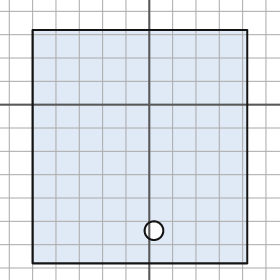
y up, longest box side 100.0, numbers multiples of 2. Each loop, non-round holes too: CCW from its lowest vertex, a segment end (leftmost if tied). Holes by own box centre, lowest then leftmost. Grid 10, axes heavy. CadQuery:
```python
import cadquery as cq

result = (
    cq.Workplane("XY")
    .moveTo(-50.0, -68.0)
    .lineTo(42.0, -68.0)
    .lineTo(42.0, 32.0)
    .lineTo(-50.0, 32.0)
    .close()
    .moveTo(2.0, -54.0)
    .circle(4.0)
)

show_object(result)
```